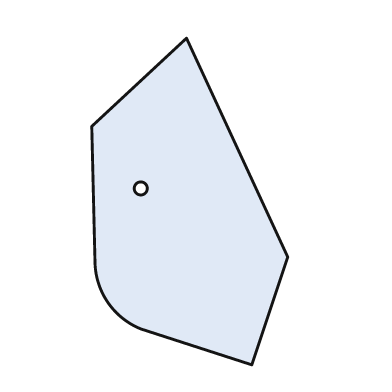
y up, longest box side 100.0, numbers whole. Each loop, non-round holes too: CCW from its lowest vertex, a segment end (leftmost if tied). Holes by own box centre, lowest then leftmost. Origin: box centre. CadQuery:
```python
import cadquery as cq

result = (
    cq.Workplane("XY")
    .moveTo(19.0, -50.0)
    .lineTo(30.0, -17.0)
    .lineTo(-1.0, 50.0)
    .lineTo(-30.0, 23.0)
    .lineTo(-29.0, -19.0)
    .threePointArc((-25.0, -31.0), (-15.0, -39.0))
    .close()
    .moveTo(-15.0, 4.0)
    .circle(2.0)
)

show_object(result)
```